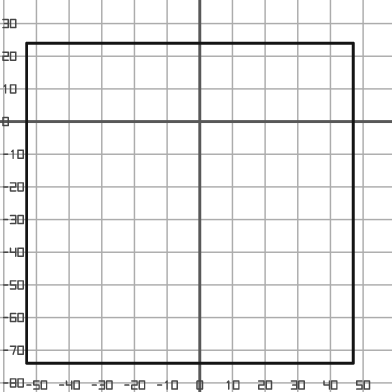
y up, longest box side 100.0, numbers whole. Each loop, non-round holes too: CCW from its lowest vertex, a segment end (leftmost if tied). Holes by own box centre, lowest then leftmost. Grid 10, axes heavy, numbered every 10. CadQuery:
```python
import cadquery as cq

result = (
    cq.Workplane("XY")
    .moveTo(-53.0, -74.0)
    .lineTo(47.0, -74.0)
    .lineTo(47.0, 24.0)
    .lineTo(-53.0, 24.0)
    .close()
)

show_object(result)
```